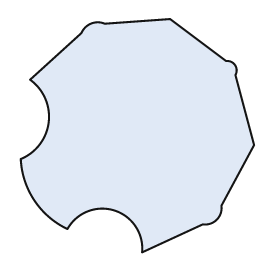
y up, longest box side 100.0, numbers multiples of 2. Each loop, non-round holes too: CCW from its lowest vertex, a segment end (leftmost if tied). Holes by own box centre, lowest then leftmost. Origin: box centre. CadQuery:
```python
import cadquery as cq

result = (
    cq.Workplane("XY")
    .moveTo(2.0, -50.0)
    .lineTo(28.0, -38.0)
    .threePointArc((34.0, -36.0), (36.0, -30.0))
    .lineTo(50.0, -4.0)
    .lineTo(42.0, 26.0)
    .threePointArc((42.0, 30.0), (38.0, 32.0))
    .lineTo(14.0, 50.0)
    .lineTo(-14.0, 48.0)
    .threePointArc((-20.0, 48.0), (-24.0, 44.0))
    .lineTo(-46.0, 24.0)
    .threePointArc((-38.0, 6.0), (-50.0, -10.0))
    .threePointArc((-44.0, -28.0), (-30.0, -40.0))
    .threePointArc((-10.0, -32.0), (2.0, -50.0))
    .close()
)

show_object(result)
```